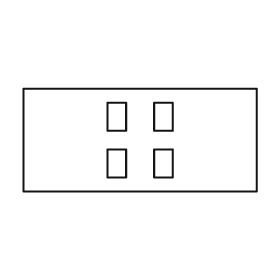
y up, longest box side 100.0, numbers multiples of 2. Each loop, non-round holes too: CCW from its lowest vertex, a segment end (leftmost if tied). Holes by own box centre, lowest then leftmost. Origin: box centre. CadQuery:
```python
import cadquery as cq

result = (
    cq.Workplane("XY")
    .moveTo(-50.0, -22.0)
    .lineTo(50.0, -22.0)
    .lineTo(50.0, 22.0)
    .lineTo(-50.0, 22.0)
    .close()
    .moveTo(-14.0, -16.0)
    .lineTo(-6.0, -16.0)
    .lineTo(-6.0, -4.0)
    .lineTo(-14.0, -4.0)
    .close()
    .moveTo(6.0, -16.0)
    .lineTo(14.0, -16.0)
    .lineTo(14.0, -4.0)
    .lineTo(6.0, -4.0)
    .close()
    .moveTo(-14.0, 4.0)
    .lineTo(-6.0, 4.0)
    .lineTo(-6.0, 16.0)
    .lineTo(-14.0, 16.0)
    .close()
    .moveTo(6.0, 4.0)
    .lineTo(14.0, 4.0)
    .lineTo(14.0, 16.0)
    .lineTo(6.0, 16.0)
    .close()
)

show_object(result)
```